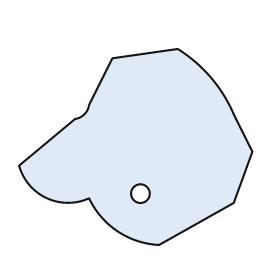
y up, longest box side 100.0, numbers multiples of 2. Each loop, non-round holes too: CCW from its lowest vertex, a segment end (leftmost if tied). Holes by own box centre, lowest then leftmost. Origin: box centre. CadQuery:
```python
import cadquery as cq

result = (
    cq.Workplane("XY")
    .moveTo(10.0, -42.0)
    .lineTo(42.0, -24.0)
    .lineTo(50.0, -2.0)
    .lineTo(42.0, 14.0)
    .threePointArc((32.0, 30.0), (18.0, 42.0))
    .lineTo(-10.0, 38.0)
    .lineTo(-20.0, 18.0)
    .threePointArc((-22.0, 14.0), (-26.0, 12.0))
    .lineTo(-50.0, -8.0)
    .threePointArc((-38.0, -22.0), (-20.0, -22.0))
    .threePointArc((-8.0, -36.0), (10.0, -42.0))
    .close()
    .moveTo(2.0, -20.0)
    .circle(4.0)
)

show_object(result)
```